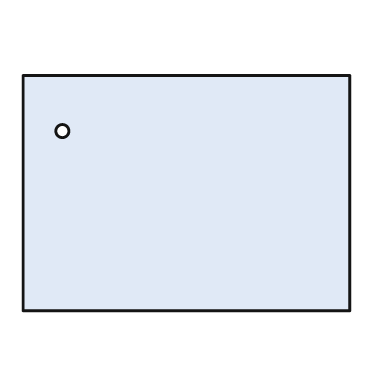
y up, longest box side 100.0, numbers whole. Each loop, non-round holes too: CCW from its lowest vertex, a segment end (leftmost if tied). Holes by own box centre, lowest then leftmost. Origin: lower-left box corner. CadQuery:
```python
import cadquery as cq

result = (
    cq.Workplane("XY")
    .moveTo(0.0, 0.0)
    .lineTo(100.0, 0.0)
    .lineTo(100.0, 72.0)
    .lineTo(0.0, 72.0)
    .close()
    .moveTo(12.0, 55.0)
    .circle(2.0)
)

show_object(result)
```